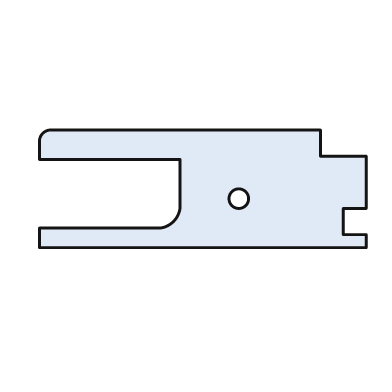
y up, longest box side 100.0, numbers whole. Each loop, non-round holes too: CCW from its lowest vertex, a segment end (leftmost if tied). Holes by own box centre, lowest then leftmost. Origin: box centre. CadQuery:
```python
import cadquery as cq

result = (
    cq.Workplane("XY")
    .moveTo(-50.0, -18.0)
    .lineTo(50.0, -18.0)
    .lineTo(50.0, -14.0)
    .lineTo(43.0, -14.0)
    .lineTo(43.0, -6.0)
    .lineTo(50.0, -6.0)
    .lineTo(50.0, 10.0)
    .lineTo(36.0, 10.0)
    .lineTo(36.0, 18.0)
    .lineTo(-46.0, 18.0)
    .threePointArc((-49.0, 17.0), (-50.0, 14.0))
    .lineTo(-50.0, 9.0)
    .lineTo(-7.0, 9.0)
    .lineTo(-7.0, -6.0)
    .threePointArc((-9.0, -10.0), (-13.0, -12.0))
    .lineTo(-50.0, -12.0)
    .close()
    .moveTo(11.0, -3.0)
    .circle(3.0)
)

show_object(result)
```